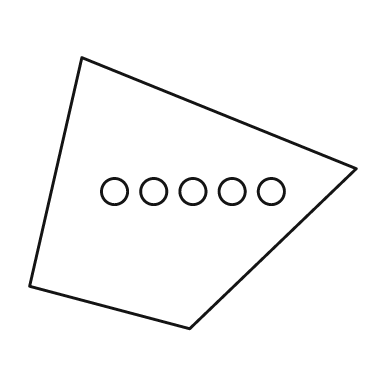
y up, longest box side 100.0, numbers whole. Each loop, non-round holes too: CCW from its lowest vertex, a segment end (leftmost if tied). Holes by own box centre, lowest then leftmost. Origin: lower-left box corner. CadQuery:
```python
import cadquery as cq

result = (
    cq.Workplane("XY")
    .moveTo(49.0, 0.0)
    .lineTo(100.0, 49.0)
    .lineTo(16.0, 83.0)
    .lineTo(0.0, 13.0)
    .close()
    .moveTo(26.0, 42.0)
    .circle(4.0)
    .moveTo(38.0, 42.0)
    .circle(4.0)
    .moveTo(50.0, 42.0)
    .circle(4.0)
    .moveTo(62.0, 42.0)
    .circle(4.0)
    .moveTo(74.0, 42.0)
    .circle(4.0)
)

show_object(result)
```